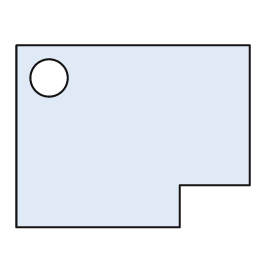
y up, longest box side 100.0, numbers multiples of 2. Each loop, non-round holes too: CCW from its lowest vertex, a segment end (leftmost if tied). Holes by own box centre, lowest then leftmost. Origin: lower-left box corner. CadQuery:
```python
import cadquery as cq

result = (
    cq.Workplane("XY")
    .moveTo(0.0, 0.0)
    .lineTo(70.0, 0.0)
    .lineTo(70.0, 18.0)
    .lineTo(100.0, 18.0)
    .lineTo(100.0, 78.0)
    .lineTo(0.0, 78.0)
    .close()
    .moveTo(14.0, 64.0)
    .circle(8.0)
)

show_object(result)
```